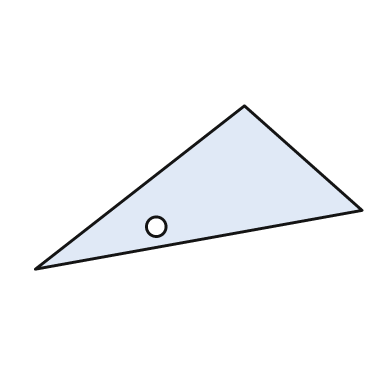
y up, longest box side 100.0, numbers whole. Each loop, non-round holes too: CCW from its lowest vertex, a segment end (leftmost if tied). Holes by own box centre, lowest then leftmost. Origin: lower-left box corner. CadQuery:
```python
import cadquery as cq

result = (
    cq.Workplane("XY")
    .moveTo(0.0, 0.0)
    .lineTo(100.0, 18.0)
    .lineTo(64.0, 50.0)
    .close()
    .moveTo(37.0, 13.0)
    .circle(3.0)
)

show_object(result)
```